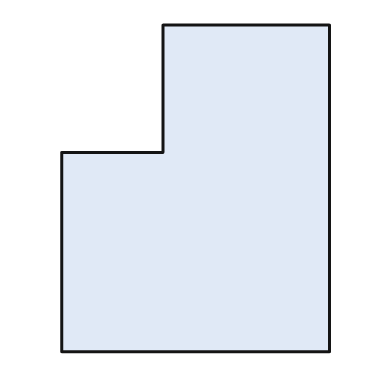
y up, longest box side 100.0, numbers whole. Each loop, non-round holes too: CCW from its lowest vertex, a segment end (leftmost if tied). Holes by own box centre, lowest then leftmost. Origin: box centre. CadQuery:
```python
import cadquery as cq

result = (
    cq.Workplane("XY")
    .moveTo(-41.0, -50.0)
    .lineTo(41.0, -50.0)
    .lineTo(41.0, 50.0)
    .lineTo(-10.0, 50.0)
    .lineTo(-10.0, 11.0)
    .lineTo(-41.0, 11.0)
    .close()
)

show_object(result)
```